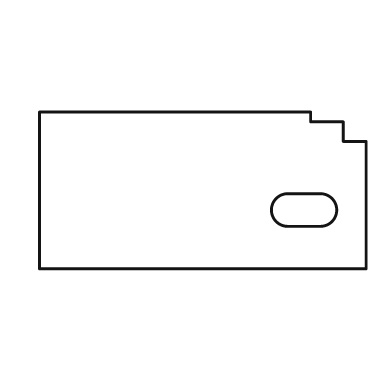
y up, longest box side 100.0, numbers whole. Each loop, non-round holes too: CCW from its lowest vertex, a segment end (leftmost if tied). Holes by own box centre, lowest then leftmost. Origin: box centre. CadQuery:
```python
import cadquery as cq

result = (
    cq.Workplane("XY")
    .moveTo(-50.0, -24.0)
    .lineTo(50.0, -24.0)
    .lineTo(50.0, 15.0)
    .lineTo(43.0, 15.0)
    .lineTo(43.0, 21.0)
    .lineTo(33.0, 21.0)
    .lineTo(33.0, 24.0)
    .lineTo(-50.0, 24.0)
    .close()
    .moveTo(26.0, -11.0)
    .lineTo(36.0, -11.0)
    .threePointArc((41.0, -6.0), (36.0, -1.0))
    .lineTo(26.0, -1.0)
    .threePointArc((21.0, -6.0), (26.0, -11.0))
    .close()
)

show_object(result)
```